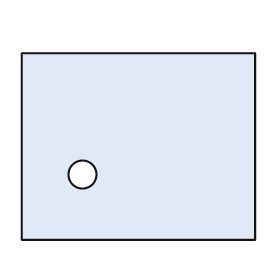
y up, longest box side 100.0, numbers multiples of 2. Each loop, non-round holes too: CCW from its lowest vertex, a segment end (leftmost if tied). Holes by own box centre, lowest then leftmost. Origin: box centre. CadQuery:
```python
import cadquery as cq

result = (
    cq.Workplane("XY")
    .moveTo(-50.0, -40.0)
    .lineTo(50.0, -40.0)
    .lineTo(50.0, 40.0)
    .lineTo(-50.0, 40.0)
    .close()
    .moveTo(-24.0, -12.0)
    .circle(6.0)
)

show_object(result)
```